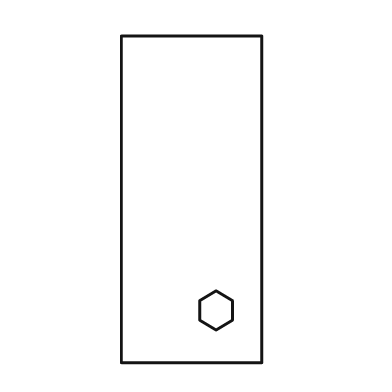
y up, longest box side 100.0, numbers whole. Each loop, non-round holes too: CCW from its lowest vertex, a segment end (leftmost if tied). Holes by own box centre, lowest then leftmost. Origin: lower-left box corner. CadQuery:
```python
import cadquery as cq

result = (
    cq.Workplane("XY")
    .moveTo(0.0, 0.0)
    .lineTo(43.0, 0.0)
    .lineTo(43.0, 100.0)
    .lineTo(0.0, 100.0)
    .close()
    .moveTo(29.0, 10.0)
    .lineTo(34.0, 13.0)
    .lineTo(34.0, 19.0)
    .lineTo(29.0, 22.0)
    .lineTo(24.0, 19.0)
    .lineTo(24.0, 13.0)
    .close()
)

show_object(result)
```